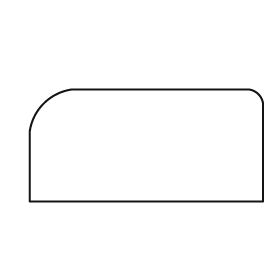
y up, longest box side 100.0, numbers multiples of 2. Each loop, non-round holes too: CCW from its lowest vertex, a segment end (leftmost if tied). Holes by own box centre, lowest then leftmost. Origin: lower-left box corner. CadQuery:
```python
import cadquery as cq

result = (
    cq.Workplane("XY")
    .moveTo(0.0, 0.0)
    .lineTo(100.0, 0.0)
    .lineTo(100.0, 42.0)
    .threePointArc((98.0, 46.0), (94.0, 48.0))
    .lineTo(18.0, 48.0)
    .threePointArc((6.0, 42.0), (0.0, 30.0))
    .close()
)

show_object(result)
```